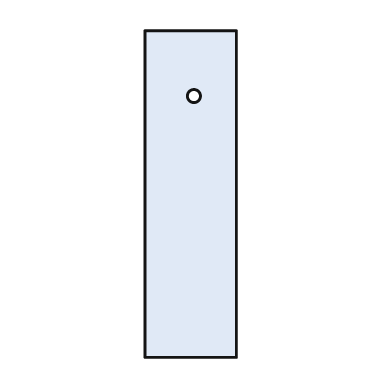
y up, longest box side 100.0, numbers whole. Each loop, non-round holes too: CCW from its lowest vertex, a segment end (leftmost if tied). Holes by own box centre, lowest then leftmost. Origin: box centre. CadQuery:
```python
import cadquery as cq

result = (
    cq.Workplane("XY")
    .moveTo(-14.0, -50.0)
    .lineTo(14.0, -50.0)
    .lineTo(14.0, 50.0)
    .lineTo(-14.0, 50.0)
    .close()
    .moveTo(1.0, 30.0)
    .circle(2.0)
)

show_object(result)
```